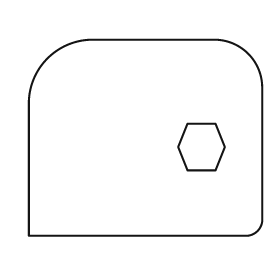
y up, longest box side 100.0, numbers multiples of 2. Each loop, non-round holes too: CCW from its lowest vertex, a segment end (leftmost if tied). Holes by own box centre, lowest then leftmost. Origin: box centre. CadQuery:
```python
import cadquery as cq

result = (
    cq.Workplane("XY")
    .moveTo(-50.0, -42.0)
    .lineTo(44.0, -42.0)
    .threePointArc((48.0, -40.0), (50.0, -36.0))
    .lineTo(50.0, 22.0)
    .threePointArc((44.0, 36.0), (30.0, 42.0))
    .lineTo(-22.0, 42.0)
    .threePointArc((-42.0, 34.0), (-50.0, 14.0))
    .close()
    .moveTo(18.0, -14.0)
    .lineTo(30.0, -14.0)
    .lineTo(34.0, -4.0)
    .lineTo(30.0, 6.0)
    .lineTo(18.0, 6.0)
    .lineTo(14.0, -4.0)
    .close()
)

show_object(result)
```